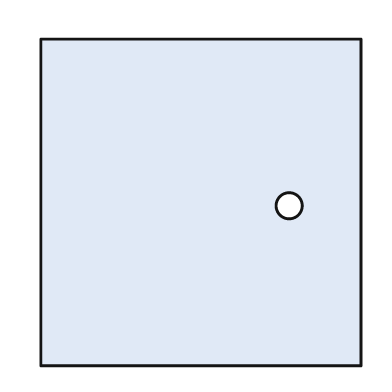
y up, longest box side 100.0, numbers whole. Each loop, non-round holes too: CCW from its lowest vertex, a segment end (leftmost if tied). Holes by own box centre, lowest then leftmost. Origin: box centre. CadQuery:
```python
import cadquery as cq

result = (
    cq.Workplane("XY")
    .moveTo(-49.0, -50.0)
    .lineTo(49.0, -50.0)
    .lineTo(49.0, 50.0)
    .lineTo(-49.0, 50.0)
    .close()
    .moveTo(27.0, -1.0)
    .circle(4.0)
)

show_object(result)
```